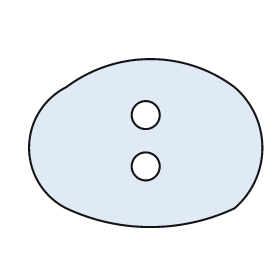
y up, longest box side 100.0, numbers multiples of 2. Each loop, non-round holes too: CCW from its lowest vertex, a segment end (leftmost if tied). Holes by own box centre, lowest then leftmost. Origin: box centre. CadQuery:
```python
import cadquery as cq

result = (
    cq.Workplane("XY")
    .moveTo(-34.0, -28.0)
    .threePointArc((2.0, -36.0), (38.0, -28.0))
    .threePointArc((50.0, -2.0), (38.0, 24.0))
    .threePointArc((2.0, 36.0), (-34.0, 24.0))
    .threePointArc((-50.0, -2.0), (-34.0, -28.0))
    .close()
    .moveTo(0.0, -10.0)
    .circle(6.0)
    .moveTo(0.0, 12.0)
    .circle(6.0)
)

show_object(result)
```